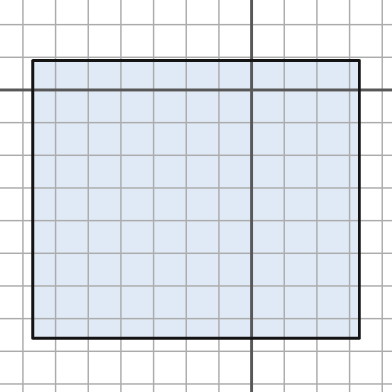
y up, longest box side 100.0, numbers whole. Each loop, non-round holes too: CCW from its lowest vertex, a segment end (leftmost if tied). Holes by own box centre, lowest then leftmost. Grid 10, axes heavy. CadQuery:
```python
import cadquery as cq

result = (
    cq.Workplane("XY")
    .moveTo(-67.0, -76.0)
    .lineTo(33.0, -76.0)
    .lineTo(33.0, 9.0)
    .lineTo(-67.0, 9.0)
    .close()
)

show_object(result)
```